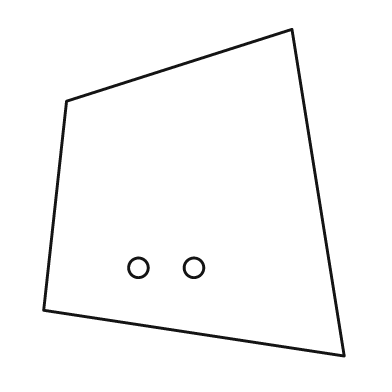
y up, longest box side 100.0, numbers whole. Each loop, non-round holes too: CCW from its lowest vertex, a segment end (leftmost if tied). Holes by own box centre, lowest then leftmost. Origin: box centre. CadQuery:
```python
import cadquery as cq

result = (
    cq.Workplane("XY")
    .moveTo(46.0, -50.0)
    .lineTo(30.0, 50.0)
    .lineTo(-39.0, 28.0)
    .lineTo(-46.0, -36.0)
    .close()
    .moveTo(-17.0, -23.0)
    .circle(3.0)
    .moveTo(0.0, -23.0)
    .circle(3.0)
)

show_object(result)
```